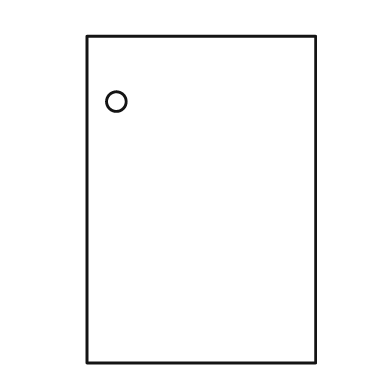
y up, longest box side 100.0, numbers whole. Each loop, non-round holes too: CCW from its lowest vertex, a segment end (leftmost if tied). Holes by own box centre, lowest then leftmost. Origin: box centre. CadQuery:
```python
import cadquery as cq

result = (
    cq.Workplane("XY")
    .moveTo(-35.0, -50.0)
    .lineTo(35.0, -50.0)
    .lineTo(35.0, 50.0)
    .lineTo(-35.0, 50.0)
    .close()
    .moveTo(-26.0, 30.0)
    .circle(3.0)
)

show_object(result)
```